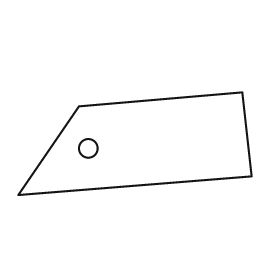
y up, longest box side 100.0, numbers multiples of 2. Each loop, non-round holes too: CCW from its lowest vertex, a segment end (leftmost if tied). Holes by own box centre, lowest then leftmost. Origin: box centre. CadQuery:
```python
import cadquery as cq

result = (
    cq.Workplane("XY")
    .moveTo(-50.0, -22.0)
    .lineTo(50.0, -14.0)
    .lineTo(46.0, 22.0)
    .lineTo(-24.0, 16.0)
    .close()
    .moveTo(-20.0, -2.0)
    .circle(4.0)
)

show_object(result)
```